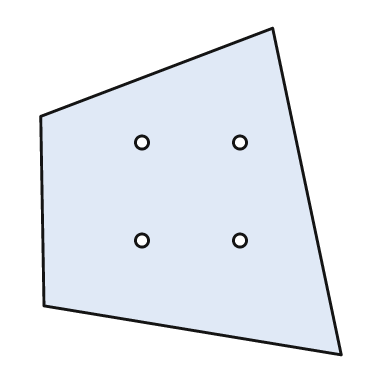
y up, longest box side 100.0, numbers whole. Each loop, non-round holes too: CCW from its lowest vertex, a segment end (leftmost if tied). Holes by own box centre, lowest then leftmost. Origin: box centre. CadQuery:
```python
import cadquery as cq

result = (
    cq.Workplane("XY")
    .moveTo(46.0, -50.0)
    .lineTo(25.0, 50.0)
    .lineTo(-46.0, 23.0)
    .lineTo(-45.0, -35.0)
    .close()
    .moveTo(-15.0, -15.0)
    .circle(2.0)
    .moveTo(15.0, -15.0)
    .circle(2.0)
    .moveTo(-15.0, 15.0)
    .circle(2.0)
    .moveTo(15.0, 15.0)
    .circle(2.0)
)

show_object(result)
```